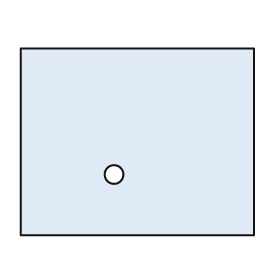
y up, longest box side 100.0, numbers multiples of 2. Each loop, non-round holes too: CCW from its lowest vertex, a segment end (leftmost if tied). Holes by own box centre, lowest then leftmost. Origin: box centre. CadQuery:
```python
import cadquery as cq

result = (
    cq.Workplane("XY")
    .moveTo(-50.0, -40.0)
    .lineTo(50.0, -40.0)
    .lineTo(50.0, 40.0)
    .lineTo(-50.0, 40.0)
    .close()
    .moveTo(-10.0, -14.0)
    .circle(4.0)
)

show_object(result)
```